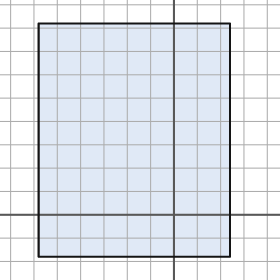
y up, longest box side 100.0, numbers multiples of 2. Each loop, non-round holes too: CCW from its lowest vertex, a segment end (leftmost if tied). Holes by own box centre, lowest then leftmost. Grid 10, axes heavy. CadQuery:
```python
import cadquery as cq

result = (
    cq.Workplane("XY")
    .moveTo(-58.0, -18.0)
    .lineTo(24.0, -18.0)
    .lineTo(24.0, 82.0)
    .lineTo(-58.0, 82.0)
    .close()
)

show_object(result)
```